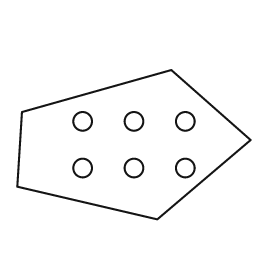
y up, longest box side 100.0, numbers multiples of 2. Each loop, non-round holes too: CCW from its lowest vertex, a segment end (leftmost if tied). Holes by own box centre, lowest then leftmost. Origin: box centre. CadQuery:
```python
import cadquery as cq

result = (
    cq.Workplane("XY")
    .moveTo(10.0, -32.0)
    .lineTo(50.0, 2.0)
    .lineTo(16.0, 32.0)
    .lineTo(-48.0, 14.0)
    .lineTo(-50.0, -18.0)
    .close()
    .moveTo(-22.0, -10.0)
    .circle(4.0)
    .moveTo(0.0, -10.0)
    .circle(4.0)
    .moveTo(22.0, -10.0)
    .circle(4.0)
    .moveTo(-22.0, 10.0)
    .circle(4.0)
    .moveTo(0.0, 10.0)
    .circle(4.0)
    .moveTo(22.0, 10.0)
    .circle(4.0)
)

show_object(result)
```